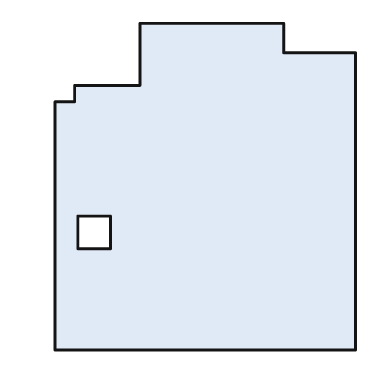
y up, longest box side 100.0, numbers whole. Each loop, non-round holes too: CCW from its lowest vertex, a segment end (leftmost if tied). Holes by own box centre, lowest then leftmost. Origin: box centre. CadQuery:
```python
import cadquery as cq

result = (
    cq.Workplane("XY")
    .moveTo(-46.0, -50.0)
    .lineTo(46.0, -50.0)
    .lineTo(46.0, 41.0)
    .lineTo(24.0, 41.0)
    .lineTo(24.0, 50.0)
    .lineTo(-20.0, 50.0)
    .lineTo(-20.0, 31.0)
    .lineTo(-40.0, 31.0)
    .lineTo(-40.0, 26.0)
    .lineTo(-46.0, 26.0)
    .close()
    .moveTo(-39.0, -19.0)
    .lineTo(-29.0, -19.0)
    .lineTo(-29.0, -9.0)
    .lineTo(-39.0, -9.0)
    .close()
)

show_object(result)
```